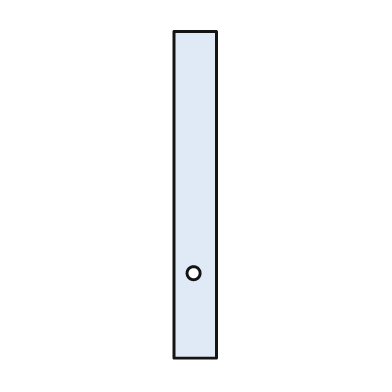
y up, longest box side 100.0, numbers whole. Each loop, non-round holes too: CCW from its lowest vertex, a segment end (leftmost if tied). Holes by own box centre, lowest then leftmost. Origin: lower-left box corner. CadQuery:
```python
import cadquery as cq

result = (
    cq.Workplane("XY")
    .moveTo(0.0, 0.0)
    .lineTo(13.0, 0.0)
    .lineTo(13.0, 100.0)
    .lineTo(0.0, 100.0)
    .close()
    .moveTo(6.0, 26.0)
    .circle(2.0)
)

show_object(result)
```